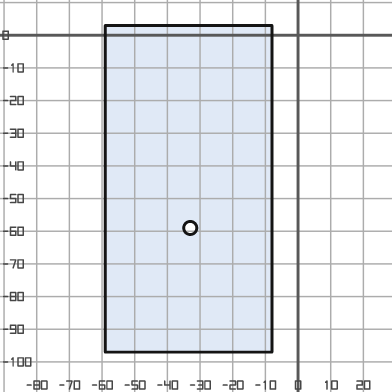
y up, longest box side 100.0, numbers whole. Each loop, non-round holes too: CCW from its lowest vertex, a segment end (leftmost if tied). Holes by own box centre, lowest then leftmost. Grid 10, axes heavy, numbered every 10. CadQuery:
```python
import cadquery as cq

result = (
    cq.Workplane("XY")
    .moveTo(-59.0, -97.0)
    .lineTo(-8.0, -97.0)
    .lineTo(-8.0, 3.0)
    .lineTo(-59.0, 3.0)
    .close()
    .moveTo(-33.0, -59.0)
    .circle(2.0)
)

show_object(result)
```